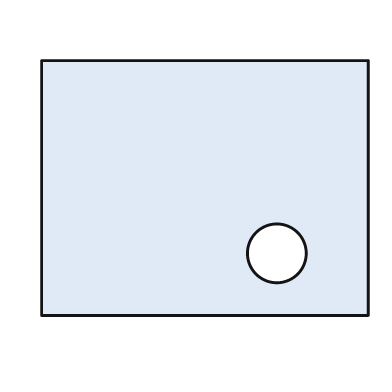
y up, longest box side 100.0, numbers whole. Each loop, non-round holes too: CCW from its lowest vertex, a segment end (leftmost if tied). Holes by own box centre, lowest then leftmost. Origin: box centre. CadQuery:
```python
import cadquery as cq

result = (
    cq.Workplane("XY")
    .moveTo(-50.0, -39.0)
    .lineTo(50.0, -39.0)
    .lineTo(50.0, 39.0)
    .lineTo(-50.0, 39.0)
    .close()
    .moveTo(22.0, -20.0)
    .circle(9.0)
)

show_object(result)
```